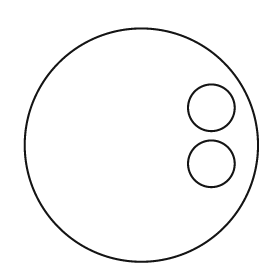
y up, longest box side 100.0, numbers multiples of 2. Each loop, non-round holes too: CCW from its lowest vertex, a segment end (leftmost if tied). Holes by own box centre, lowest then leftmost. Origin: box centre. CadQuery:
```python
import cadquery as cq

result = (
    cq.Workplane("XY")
    .moveTo(0.0, 0.0)
    .circle(50.0)
    .moveTo(30.0, -8.0)
    .circle(10.0)
    .moveTo(30.0, 16.0)
    .circle(10.0)
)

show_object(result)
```